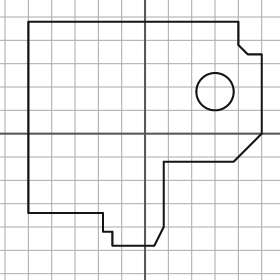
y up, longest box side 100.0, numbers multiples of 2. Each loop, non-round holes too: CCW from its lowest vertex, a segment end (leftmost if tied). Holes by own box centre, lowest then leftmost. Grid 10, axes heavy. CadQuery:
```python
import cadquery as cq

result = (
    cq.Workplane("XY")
    .moveTo(-14.0, -48.0)
    .lineTo(4.0, -48.0)
    .lineTo(8.0, -40.0)
    .lineTo(8.0, -12.0)
    .lineTo(38.0, -12.0)
    .lineTo(50.0, 0.0)
    .lineTo(50.0, 34.0)
    .lineTo(44.0, 34.0)
    .lineTo(40.0, 38.0)
    .lineTo(40.0, 48.0)
    .lineTo(-50.0, 48.0)
    .lineTo(-50.0, -34.0)
    .lineTo(-18.0, -34.0)
    .lineTo(-18.0, -42.0)
    .lineTo(-14.0, -42.0)
    .close()
    .moveTo(30.0, 18.0)
    .circle(8.0)
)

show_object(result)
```